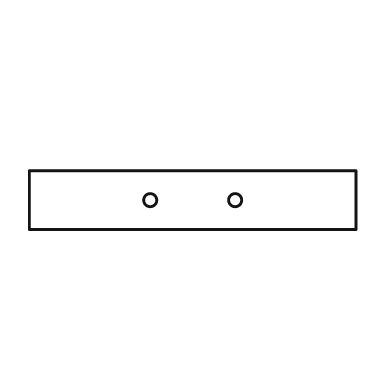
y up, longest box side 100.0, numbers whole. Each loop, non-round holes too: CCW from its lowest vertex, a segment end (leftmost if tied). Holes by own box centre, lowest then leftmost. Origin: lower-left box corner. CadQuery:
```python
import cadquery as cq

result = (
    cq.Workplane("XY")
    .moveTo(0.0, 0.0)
    .lineTo(100.0, 0.0)
    .lineTo(100.0, 18.0)
    .lineTo(0.0, 18.0)
    .close()
    .moveTo(37.0, 9.0)
    .circle(2.0)
    .moveTo(63.0, 9.0)
    .circle(2.0)
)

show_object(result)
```